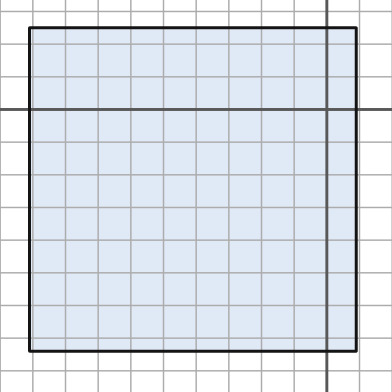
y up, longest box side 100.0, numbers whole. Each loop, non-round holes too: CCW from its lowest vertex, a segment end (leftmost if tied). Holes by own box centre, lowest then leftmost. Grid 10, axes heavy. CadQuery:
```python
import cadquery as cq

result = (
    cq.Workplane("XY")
    .moveTo(-91.0, -74.0)
    .lineTo(9.0, -74.0)
    .lineTo(9.0, 25.0)
    .lineTo(-91.0, 25.0)
    .close()
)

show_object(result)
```